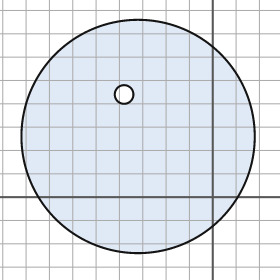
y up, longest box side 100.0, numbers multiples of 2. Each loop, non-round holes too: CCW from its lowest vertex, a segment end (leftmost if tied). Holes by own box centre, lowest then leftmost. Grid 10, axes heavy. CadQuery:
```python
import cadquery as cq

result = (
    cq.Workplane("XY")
    .moveTo(-32.0, 26.0)
    .circle(50.0)
    .moveTo(-38.0, 44.0)
    .circle(4.0)
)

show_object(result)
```